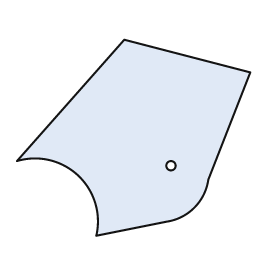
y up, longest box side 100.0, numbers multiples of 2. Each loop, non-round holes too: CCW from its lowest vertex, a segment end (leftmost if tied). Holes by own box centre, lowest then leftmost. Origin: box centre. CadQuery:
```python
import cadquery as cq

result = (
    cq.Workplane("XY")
    .moveTo(-16.0, -42.0)
    .lineTo(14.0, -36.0)
    .threePointArc((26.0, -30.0), (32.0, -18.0))
    .lineTo(50.0, 28.0)
    .lineTo(-4.0, 42.0)
    .lineTo(-50.0, -10.0)
    .threePointArc((-24.0, -16.0), (-16.0, -42.0))
    .close()
    .moveTo(16.0, -12.0)
    .circle(2.0)
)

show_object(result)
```